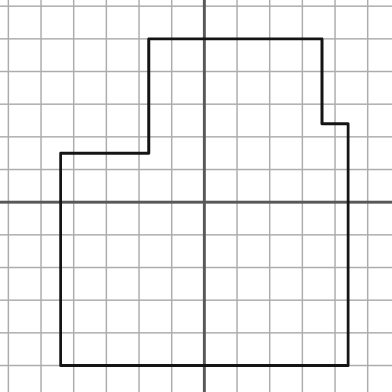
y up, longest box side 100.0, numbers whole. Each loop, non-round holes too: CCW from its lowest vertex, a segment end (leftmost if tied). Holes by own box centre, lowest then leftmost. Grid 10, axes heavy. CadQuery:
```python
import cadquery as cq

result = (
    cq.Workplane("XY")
    .moveTo(-44.0, -50.0)
    .lineTo(44.0, -50.0)
    .lineTo(44.0, 24.0)
    .lineTo(36.0, 24.0)
    .lineTo(36.0, 50.0)
    .lineTo(-17.0, 50.0)
    .lineTo(-17.0, 15.0)
    .lineTo(-44.0, 15.0)
    .close()
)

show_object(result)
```